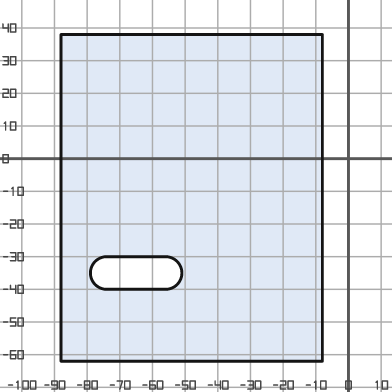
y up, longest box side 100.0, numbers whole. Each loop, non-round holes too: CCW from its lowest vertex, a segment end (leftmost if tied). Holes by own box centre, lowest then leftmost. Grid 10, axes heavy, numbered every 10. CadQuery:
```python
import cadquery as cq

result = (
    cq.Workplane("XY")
    .moveTo(-88.0, -62.0)
    .lineTo(-8.0, -62.0)
    .lineTo(-8.0, 38.0)
    .lineTo(-88.0, 38.0)
    .close()
    .moveTo(-74.0, -40.0)
    .lineTo(-56.0, -40.0)
    .threePointArc((-51.0, -35.0), (-56.0, -30.0))
    .lineTo(-74.0, -30.0)
    .threePointArc((-79.0, -35.0), (-74.0, -40.0))
    .close()
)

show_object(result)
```